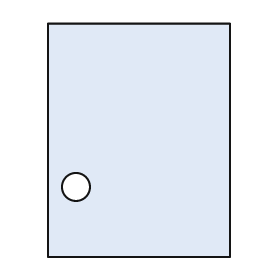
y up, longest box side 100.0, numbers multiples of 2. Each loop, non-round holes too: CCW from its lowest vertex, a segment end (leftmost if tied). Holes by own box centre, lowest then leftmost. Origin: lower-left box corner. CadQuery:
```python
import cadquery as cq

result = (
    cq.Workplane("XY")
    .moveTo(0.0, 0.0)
    .lineTo(78.0, 0.0)
    .lineTo(78.0, 100.0)
    .lineTo(0.0, 100.0)
    .close()
    .moveTo(12.0, 30.0)
    .circle(6.0)
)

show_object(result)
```